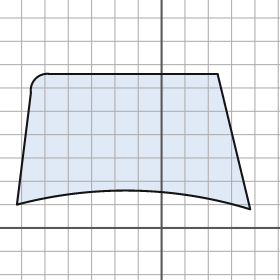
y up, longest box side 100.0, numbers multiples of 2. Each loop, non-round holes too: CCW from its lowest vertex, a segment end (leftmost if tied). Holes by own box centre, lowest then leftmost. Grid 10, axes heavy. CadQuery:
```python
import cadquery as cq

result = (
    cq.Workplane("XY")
    .moveTo(38.0, 8.0)
    .lineTo(24.0, 66.0)
    .lineTo(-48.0, 66.0)
    .threePointArc((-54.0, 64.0), (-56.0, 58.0))
    .lineTo(-62.0, 10.0)
    .threePointArc((-12.0, 16.0), (38.0, 8.0))
    .close()
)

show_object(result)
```